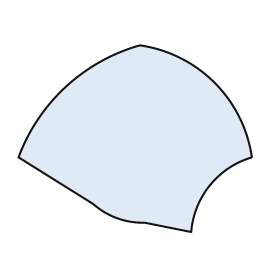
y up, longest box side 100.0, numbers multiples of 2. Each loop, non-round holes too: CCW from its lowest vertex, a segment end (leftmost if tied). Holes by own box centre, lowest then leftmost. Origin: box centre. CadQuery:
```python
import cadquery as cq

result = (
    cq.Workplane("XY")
    .moveTo(24.0, -40.0)
    .threePointArc((32.0, -20.0), (50.0, -8.0))
    .threePointArc((34.0, 24.0), (2.0, 40.0))
    .threePointArc((-30.0, 22.0), (-50.0, -8.0))
    .lineTo(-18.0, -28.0)
    .threePointArc((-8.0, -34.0), (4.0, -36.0))
    .close()
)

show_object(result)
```